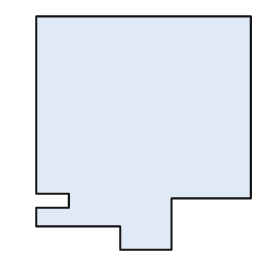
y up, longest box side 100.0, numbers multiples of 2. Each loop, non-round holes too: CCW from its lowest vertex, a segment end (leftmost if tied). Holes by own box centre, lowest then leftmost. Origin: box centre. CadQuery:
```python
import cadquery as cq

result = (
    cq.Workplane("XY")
    .moveTo(-10.0, -50.0)
    .lineTo(12.0, -50.0)
    .lineTo(12.0, -28.0)
    .lineTo(46.0, -28.0)
    .lineTo(46.0, 50.0)
    .lineTo(-46.0, 50.0)
    .lineTo(-46.0, -26.0)
    .lineTo(-32.0, -26.0)
    .lineTo(-32.0, -32.0)
    .lineTo(-46.0, -32.0)
    .lineTo(-46.0, -40.0)
    .lineTo(-10.0, -40.0)
    .close()
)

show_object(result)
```